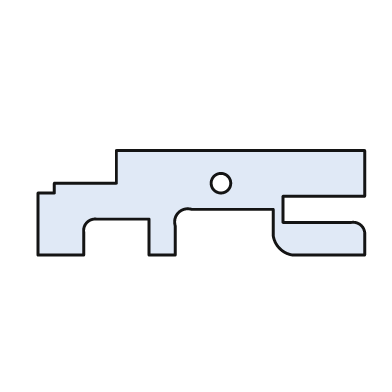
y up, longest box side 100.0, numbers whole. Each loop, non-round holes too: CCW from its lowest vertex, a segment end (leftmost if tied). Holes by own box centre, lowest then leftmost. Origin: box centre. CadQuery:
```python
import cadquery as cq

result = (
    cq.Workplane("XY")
    .moveTo(-50.0, -16.0)
    .lineTo(-36.0, -16.0)
    .lineTo(-36.0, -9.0)
    .threePointArc((-35.0, -6.0), (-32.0, -5.0))
    .lineTo(-16.0, -5.0)
    .lineTo(-16.0, -16.0)
    .lineTo(-8.0, -16.0)
    .lineTo(-8.0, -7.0)
    .threePointArc((-7.0, -3.0), (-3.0, -2.0))
    .lineTo(22.0, -2.0)
    .lineTo(22.0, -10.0)
    .threePointArc((24.0, -14.0), (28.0, -16.0))
    .lineTo(50.0, -16.0)
    .lineTo(50.0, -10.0)
    .threePointArc((49.0, -7.0), (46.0, -6.0))
    .lineTo(25.0, -6.0)
    .lineTo(25.0, 2.0)
    .lineTo(50.0, 2.0)
    .lineTo(50.0, 16.0)
    .lineTo(-26.0, 16.0)
    .lineTo(-26.0, 6.0)
    .lineTo(-45.0, 6.0)
    .lineTo(-45.0, 3.0)
    .lineTo(-50.0, 3.0)
    .close()
    .moveTo(6.0, 6.0)
    .circle(3.0)
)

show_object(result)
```